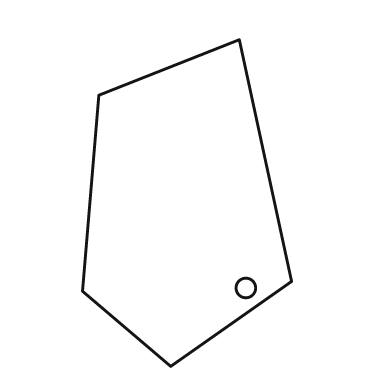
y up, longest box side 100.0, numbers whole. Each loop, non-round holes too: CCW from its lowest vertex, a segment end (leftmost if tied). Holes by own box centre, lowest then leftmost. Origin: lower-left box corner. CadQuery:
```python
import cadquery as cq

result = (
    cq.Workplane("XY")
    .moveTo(27.0, 0.0)
    .lineTo(64.0, 26.0)
    .lineTo(48.0, 100.0)
    .lineTo(5.0, 83.0)
    .lineTo(0.0, 23.0)
    .close()
    .moveTo(50.0, 24.0)
    .circle(3.0)
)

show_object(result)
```